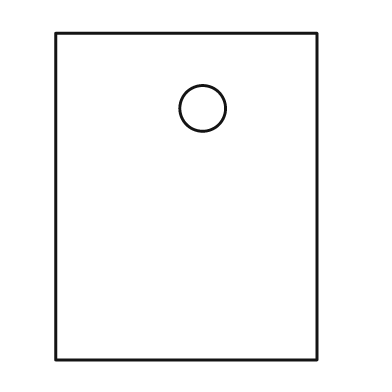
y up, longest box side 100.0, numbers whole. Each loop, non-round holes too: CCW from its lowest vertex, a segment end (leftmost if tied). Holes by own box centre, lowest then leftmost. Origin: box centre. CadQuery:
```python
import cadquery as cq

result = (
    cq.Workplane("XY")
    .moveTo(-40.0, -50.0)
    .lineTo(40.0, -50.0)
    .lineTo(40.0, 50.0)
    .lineTo(-40.0, 50.0)
    .close()
    .moveTo(5.0, 27.0)
    .circle(7.0)
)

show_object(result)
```